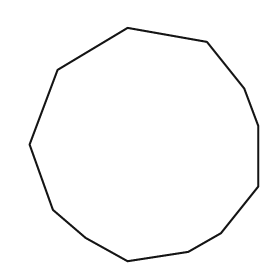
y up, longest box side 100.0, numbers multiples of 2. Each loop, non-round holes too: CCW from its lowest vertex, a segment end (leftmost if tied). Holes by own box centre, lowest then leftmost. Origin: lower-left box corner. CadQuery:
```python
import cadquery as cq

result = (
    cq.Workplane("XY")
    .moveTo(42.0, 0.0)
    .lineTo(68.0, 4.0)
    .lineTo(82.0, 12.0)
    .lineTo(98.0, 32.0)
    .lineTo(98.0, 58.0)
    .lineTo(92.0, 74.0)
    .lineTo(76.0, 94.0)
    .lineTo(42.0, 100.0)
    .lineTo(12.0, 82.0)
    .lineTo(0.0, 50.0)
    .lineTo(10.0, 22.0)
    .lineTo(24.0, 10.0)
    .close()
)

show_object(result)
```